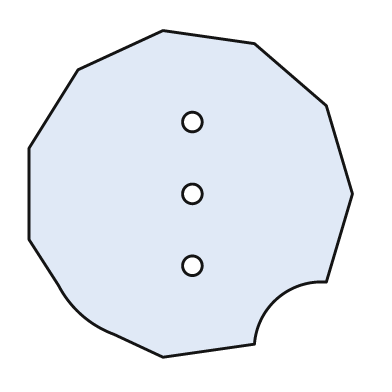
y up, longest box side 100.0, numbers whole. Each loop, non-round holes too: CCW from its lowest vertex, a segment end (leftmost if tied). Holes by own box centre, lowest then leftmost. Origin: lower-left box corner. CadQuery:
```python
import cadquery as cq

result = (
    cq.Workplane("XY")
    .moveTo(41.0, 0.0)
    .lineTo(69.0, 4.0)
    .threePointArc((76.0, 18.0), (91.0, 23.0))
    .lineTo(99.0, 50.0)
    .lineTo(91.0, 77.0)
    .lineTo(69.0, 96.0)
    .lineTo(41.0, 100.0)
    .lineTo(15.0, 88.0)
    .lineTo(0.0, 64.0)
    .lineTo(0.0, 36.0)
    .lineTo(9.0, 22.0)
    .threePointArc((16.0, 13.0), (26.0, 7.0))
    .close()
    .moveTo(50.0, 28.0)
    .circle(3.0)
    .moveTo(50.0, 50.0)
    .circle(3.0)
    .moveTo(50.0, 72.0)
    .circle(3.0)
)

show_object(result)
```